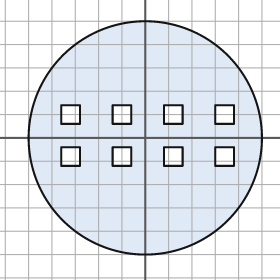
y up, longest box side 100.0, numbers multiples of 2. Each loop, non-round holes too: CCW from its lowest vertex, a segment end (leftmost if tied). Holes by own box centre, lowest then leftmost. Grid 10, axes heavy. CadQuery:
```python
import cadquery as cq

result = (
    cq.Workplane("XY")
    .moveTo(0.0, 0.0)
    .circle(50.0)
    .moveTo(-36.0, -12.0)
    .lineTo(-28.0, -12.0)
    .lineTo(-28.0, -4.0)
    .lineTo(-36.0, -4.0)
    .close()
    .moveTo(-14.0, -12.0)
    .lineTo(-6.0, -12.0)
    .lineTo(-6.0, -4.0)
    .lineTo(-14.0, -4.0)
    .close()
    .moveTo(8.0, -12.0)
    .lineTo(16.0, -12.0)
    .lineTo(16.0, -4.0)
    .lineTo(8.0, -4.0)
    .close()
    .moveTo(30.0, -12.0)
    .lineTo(38.0, -12.0)
    .lineTo(38.0, -4.0)
    .lineTo(30.0, -4.0)
    .close()
    .moveTo(-36.0, 6.0)
    .lineTo(-28.0, 6.0)
    .lineTo(-28.0, 14.0)
    .lineTo(-36.0, 14.0)
    .close()
    .moveTo(-14.0, 6.0)
    .lineTo(-6.0, 6.0)
    .lineTo(-6.0, 14.0)
    .lineTo(-14.0, 14.0)
    .close()
    .moveTo(8.0, 6.0)
    .lineTo(16.0, 6.0)
    .lineTo(16.0, 14.0)
    .lineTo(8.0, 14.0)
    .close()
    .moveTo(30.0, 6.0)
    .lineTo(38.0, 6.0)
    .lineTo(38.0, 14.0)
    .lineTo(30.0, 14.0)
    .close()
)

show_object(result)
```